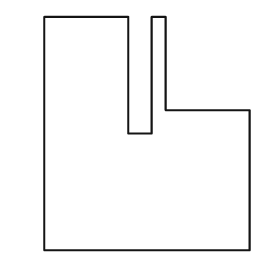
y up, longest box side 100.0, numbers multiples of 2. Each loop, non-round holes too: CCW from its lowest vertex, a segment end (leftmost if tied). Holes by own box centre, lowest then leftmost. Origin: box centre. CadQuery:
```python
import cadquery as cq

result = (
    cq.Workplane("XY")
    .moveTo(-44.0, -50.0)
    .lineTo(44.0, -50.0)
    .lineTo(44.0, 10.0)
    .lineTo(8.0, 10.0)
    .lineTo(8.0, 50.0)
    .lineTo(2.0, 50.0)
    .lineTo(2.0, 0.0)
    .lineTo(-8.0, 0.0)
    .lineTo(-8.0, 50.0)
    .lineTo(-44.0, 50.0)
    .close()
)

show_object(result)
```